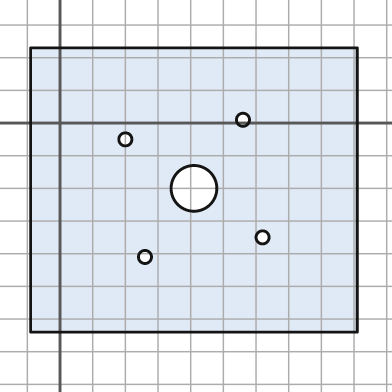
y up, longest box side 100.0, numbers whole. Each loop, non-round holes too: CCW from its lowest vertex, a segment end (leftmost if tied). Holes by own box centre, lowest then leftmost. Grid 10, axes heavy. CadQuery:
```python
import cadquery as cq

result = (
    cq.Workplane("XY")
    .moveTo(-9.0, -64.0)
    .lineTo(91.0, -64.0)
    .lineTo(91.0, 23.0)
    .lineTo(-9.0, 23.0)
    .close()
    .moveTo(26.0, -41.0)
    .circle(2.0)
    .moveTo(62.0, -35.0)
    .circle(2.0)
    .moveTo(41.0, -20.0)
    .circle(7.0)
    .moveTo(20.0, -5.0)
    .circle(2.0)
    .moveTo(56.0, 1.0)
    .circle(2.0)
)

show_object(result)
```